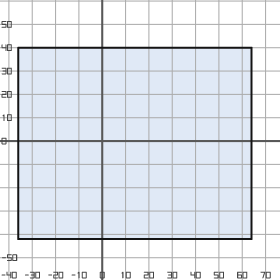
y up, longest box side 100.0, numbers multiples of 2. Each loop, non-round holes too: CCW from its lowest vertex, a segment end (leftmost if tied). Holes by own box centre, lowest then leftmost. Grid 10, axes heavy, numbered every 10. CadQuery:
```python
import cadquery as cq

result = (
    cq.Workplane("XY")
    .moveTo(-36.0, -42.0)
    .lineTo(64.0, -42.0)
    .lineTo(64.0, 40.0)
    .lineTo(-36.0, 40.0)
    .close()
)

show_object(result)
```